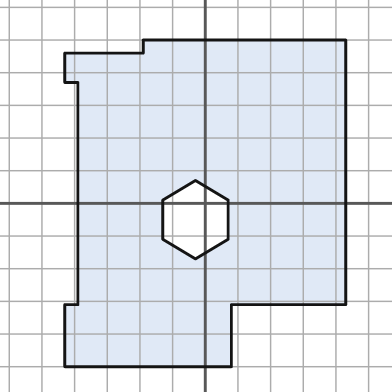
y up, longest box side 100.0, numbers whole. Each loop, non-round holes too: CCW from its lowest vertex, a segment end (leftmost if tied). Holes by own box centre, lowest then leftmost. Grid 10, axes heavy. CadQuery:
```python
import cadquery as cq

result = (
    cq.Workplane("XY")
    .moveTo(-43.0, -50.0)
    .lineTo(8.0, -50.0)
    .lineTo(8.0, -31.0)
    .lineTo(43.0, -31.0)
    .lineTo(43.0, 50.0)
    .lineTo(-19.0, 50.0)
    .lineTo(-19.0, 46.0)
    .lineTo(-43.0, 46.0)
    .lineTo(-43.0, 37.0)
    .lineTo(-39.0, 37.0)
    .lineTo(-39.0, -31.0)
    .lineTo(-43.0, -31.0)
    .close()
    .moveTo(-3.0, -17.0)
    .lineTo(7.0, -11.0)
    .lineTo(7.0, 1.0)
    .lineTo(-3.0, 7.0)
    .lineTo(-13.0, 1.0)
    .lineTo(-13.0, -11.0)
    .close()
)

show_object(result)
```